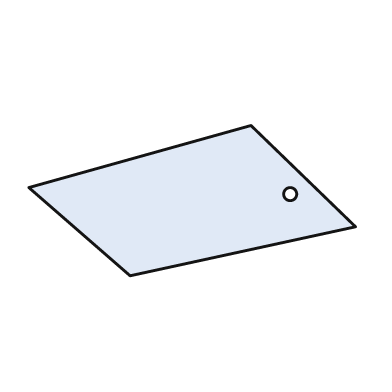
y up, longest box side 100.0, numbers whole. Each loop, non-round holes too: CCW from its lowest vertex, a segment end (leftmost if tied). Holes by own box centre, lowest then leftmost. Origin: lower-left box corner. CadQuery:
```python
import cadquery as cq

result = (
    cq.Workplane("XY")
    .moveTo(31.0, 0.0)
    .lineTo(100.0, 15.0)
    .lineTo(68.0, 46.0)
    .lineTo(0.0, 27.0)
    .close()
    .moveTo(80.0, 25.0)
    .circle(2.0)
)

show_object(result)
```